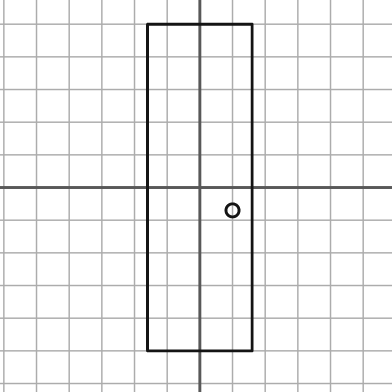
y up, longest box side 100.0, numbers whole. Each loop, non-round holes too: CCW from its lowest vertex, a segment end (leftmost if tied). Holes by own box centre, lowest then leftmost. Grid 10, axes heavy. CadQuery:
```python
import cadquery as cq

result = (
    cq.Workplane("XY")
    .moveTo(-16.0, -50.0)
    .lineTo(16.0, -50.0)
    .lineTo(16.0, 50.0)
    .lineTo(-16.0, 50.0)
    .close()
    .moveTo(10.0, -7.0)
    .circle(2.0)
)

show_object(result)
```